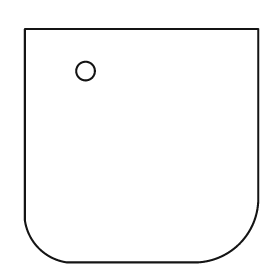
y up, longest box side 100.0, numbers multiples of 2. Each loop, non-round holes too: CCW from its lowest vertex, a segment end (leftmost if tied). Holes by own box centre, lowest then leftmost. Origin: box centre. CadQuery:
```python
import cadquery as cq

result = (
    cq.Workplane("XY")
    .moveTo(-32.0, -50.0)
    .lineTo(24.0, -50.0)
    .threePointArc((42.0, -42.0), (50.0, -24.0))
    .lineTo(50.0, 50.0)
    .lineTo(-50.0, 50.0)
    .lineTo(-50.0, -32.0)
    .threePointArc((-44.0, -44.0), (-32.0, -50.0))
    .close()
    .moveTo(-24.0, 32.0)
    .circle(4.0)
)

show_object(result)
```